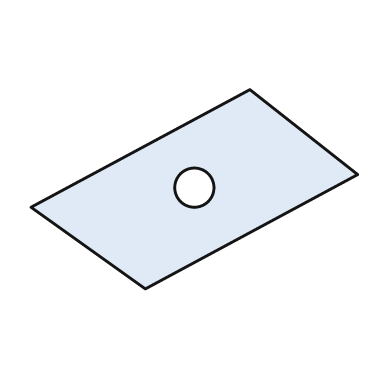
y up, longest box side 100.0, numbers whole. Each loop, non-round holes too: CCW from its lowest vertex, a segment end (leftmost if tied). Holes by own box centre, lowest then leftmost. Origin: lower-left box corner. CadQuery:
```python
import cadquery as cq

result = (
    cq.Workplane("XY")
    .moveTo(35.0, 0.0)
    .lineTo(100.0, 35.0)
    .lineTo(67.0, 61.0)
    .lineTo(0.0, 25.0)
    .close()
    .moveTo(50.0, 31.0)
    .circle(6.0)
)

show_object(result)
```